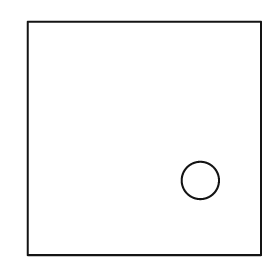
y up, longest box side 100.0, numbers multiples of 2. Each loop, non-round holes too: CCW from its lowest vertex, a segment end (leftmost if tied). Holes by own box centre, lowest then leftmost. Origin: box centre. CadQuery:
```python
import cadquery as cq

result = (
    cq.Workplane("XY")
    .moveTo(-50.0, -50.0)
    .lineTo(50.0, -50.0)
    .lineTo(50.0, 50.0)
    .lineTo(-50.0, 50.0)
    .close()
    .moveTo(24.0, -18.0)
    .circle(8.0)
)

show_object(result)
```